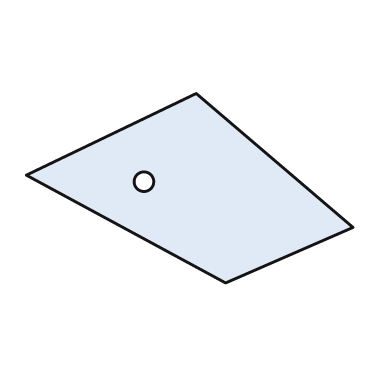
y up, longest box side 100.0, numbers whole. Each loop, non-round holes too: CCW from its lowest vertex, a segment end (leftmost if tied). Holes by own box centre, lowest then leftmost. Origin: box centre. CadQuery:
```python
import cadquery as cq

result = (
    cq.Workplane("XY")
    .moveTo(11.0, -29.0)
    .lineTo(50.0, -12.0)
    .lineTo(2.0, 29.0)
    .lineTo(-50.0, 4.0)
    .close()
    .moveTo(-14.0, 2.0)
    .circle(3.0)
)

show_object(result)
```